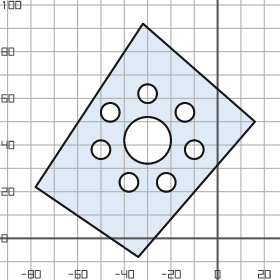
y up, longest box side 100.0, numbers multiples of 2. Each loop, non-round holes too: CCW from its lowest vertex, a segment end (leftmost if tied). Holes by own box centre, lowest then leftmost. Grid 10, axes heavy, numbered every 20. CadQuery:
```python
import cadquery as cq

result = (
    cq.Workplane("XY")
    .moveTo(-34.0, -8.0)
    .lineTo(16.0, 50.0)
    .lineTo(-32.0, 92.0)
    .lineTo(-78.0, 22.0)
    .close()
    .moveTo(-38.0, 24.0)
    .circle(4.0)
    .moveTo(-22.0, 24.0)
    .circle(4.0)
    .moveTo(-50.0, 38.0)
    .circle(4.0)
    .moveTo(-10.0, 38.0)
    .circle(4.0)
    .moveTo(-30.0, 42.0)
    .circle(10.0)
    .moveTo(-46.0, 54.0)
    .circle(4.0)
    .moveTo(-14.0, 54.0)
    .circle(4.0)
    .moveTo(-30.0, 62.0)
    .circle(4.0)
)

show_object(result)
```